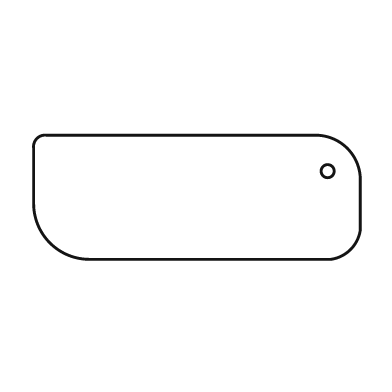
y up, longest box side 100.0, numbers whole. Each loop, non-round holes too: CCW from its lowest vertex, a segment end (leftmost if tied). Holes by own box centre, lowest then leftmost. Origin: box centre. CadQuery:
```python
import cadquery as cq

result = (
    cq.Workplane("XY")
    .moveTo(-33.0, -19.0)
    .lineTo(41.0, -19.0)
    .threePointArc((47.0, -16.0), (50.0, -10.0))
    .lineTo(50.0, 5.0)
    .threePointArc((46.0, 15.0), (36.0, 19.0))
    .lineTo(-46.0, 19.0)
    .threePointArc((-49.0, 18.0), (-50.0, 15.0))
    .lineTo(-50.0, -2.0)
    .threePointArc((-45.0, -14.0), (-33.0, -19.0))
    .close()
    .moveTo(40.0, 8.0)
    .circle(2.0)
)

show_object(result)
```